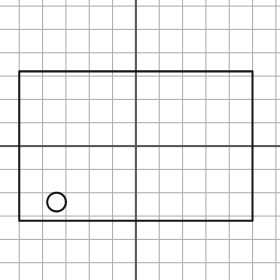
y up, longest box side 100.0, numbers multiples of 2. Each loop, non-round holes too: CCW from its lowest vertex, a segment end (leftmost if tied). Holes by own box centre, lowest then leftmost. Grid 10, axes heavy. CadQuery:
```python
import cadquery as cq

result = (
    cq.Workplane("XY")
    .moveTo(-50.0, -32.0)
    .lineTo(50.0, -32.0)
    .lineTo(50.0, 32.0)
    .lineTo(-50.0, 32.0)
    .close()
    .moveTo(-34.0, -24.0)
    .circle(4.0)
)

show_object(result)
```